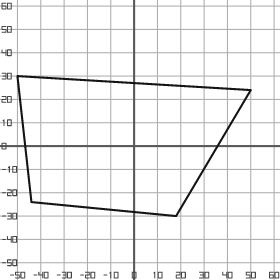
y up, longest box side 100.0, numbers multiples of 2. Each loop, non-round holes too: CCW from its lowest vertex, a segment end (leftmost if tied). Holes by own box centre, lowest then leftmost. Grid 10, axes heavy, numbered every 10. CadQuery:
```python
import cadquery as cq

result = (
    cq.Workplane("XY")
    .moveTo(18.0, -30.0)
    .lineTo(50.0, 24.0)
    .lineTo(-50.0, 30.0)
    .lineTo(-44.0, -24.0)
    .close()
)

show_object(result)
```